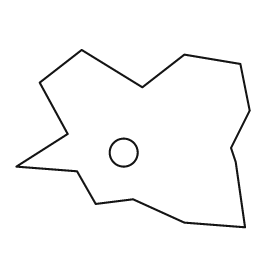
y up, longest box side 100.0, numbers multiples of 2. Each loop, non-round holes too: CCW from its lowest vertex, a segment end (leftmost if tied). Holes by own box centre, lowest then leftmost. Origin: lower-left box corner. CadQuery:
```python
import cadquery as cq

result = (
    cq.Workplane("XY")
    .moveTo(98.0, 0.0)
    .lineTo(94.0, 28.0)
    .lineTo(92.0, 34.0)
    .lineTo(100.0, 50.0)
    .lineTo(96.0, 70.0)
    .lineTo(72.0, 74.0)
    .lineTo(54.0, 60.0)
    .lineTo(28.0, 76.0)
    .lineTo(10.0, 62.0)
    .lineTo(22.0, 40.0)
    .lineTo(0.0, 26.0)
    .lineTo(26.0, 24.0)
    .lineTo(34.0, 10.0)
    .lineTo(50.0, 12.0)
    .lineTo(72.0, 2.0)
    .close()
    .moveTo(46.0, 32.0)
    .circle(6.0)
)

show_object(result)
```